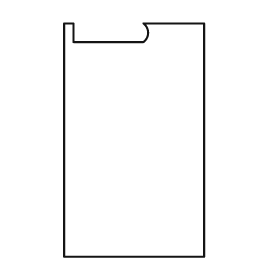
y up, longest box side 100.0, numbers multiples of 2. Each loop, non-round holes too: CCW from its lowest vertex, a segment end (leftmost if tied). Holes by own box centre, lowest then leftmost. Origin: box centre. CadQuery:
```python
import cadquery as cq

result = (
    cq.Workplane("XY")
    .moveTo(-30.0, -50.0)
    .lineTo(30.0, -50.0)
    .lineTo(30.0, 50.0)
    .lineTo(4.0, 50.0)
    .threePointArc((6.0, 46.0), (4.0, 42.0))
    .lineTo(-26.0, 42.0)
    .lineTo(-26.0, 50.0)
    .lineTo(-30.0, 50.0)
    .close()
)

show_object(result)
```